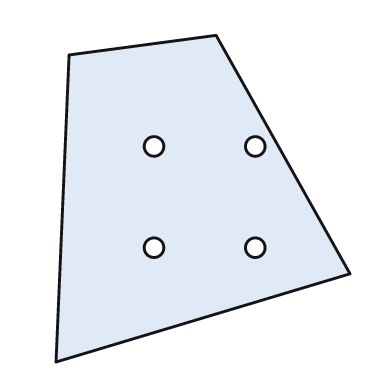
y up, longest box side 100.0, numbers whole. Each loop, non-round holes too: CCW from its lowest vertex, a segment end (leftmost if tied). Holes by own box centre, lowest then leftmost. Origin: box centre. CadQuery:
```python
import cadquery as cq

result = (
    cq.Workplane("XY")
    .moveTo(-45.0, -50.0)
    .lineTo(45.0, -23.0)
    .lineTo(4.0, 50.0)
    .lineTo(-41.0, 44.0)
    .close()
    .moveTo(-15.0, -15.0)
    .circle(3.0)
    .moveTo(16.0, -15.0)
    .circle(3.0)
    .moveTo(-15.0, 16.0)
    .circle(3.0)
    .moveTo(16.0, 16.0)
    .circle(3.0)
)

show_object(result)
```